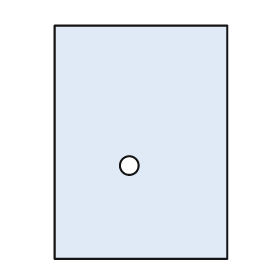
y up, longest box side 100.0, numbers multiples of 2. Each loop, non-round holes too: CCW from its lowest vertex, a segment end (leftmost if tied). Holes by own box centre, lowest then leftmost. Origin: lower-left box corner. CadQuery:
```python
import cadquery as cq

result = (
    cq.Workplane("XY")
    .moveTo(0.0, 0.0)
    .lineTo(74.0, 0.0)
    .lineTo(74.0, 100.0)
    .lineTo(0.0, 100.0)
    .close()
    .moveTo(32.0, 40.0)
    .circle(4.0)
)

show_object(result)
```